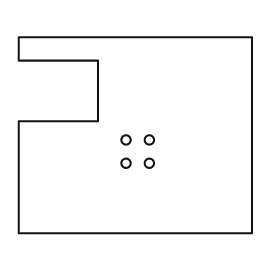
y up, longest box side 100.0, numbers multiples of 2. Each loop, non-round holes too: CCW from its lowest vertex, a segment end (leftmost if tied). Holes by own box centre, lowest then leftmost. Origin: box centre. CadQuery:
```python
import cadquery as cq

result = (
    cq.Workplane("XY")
    .moveTo(-50.0, -42.0)
    .lineTo(50.0, -42.0)
    .lineTo(50.0, 42.0)
    .lineTo(-50.0, 42.0)
    .lineTo(-50.0, 32.0)
    .lineTo(-16.0, 32.0)
    .lineTo(-16.0, 6.0)
    .lineTo(-50.0, 6.0)
    .close()
    .moveTo(-4.0, -12.0)
    .circle(2.0)
    .moveTo(6.0, -12.0)
    .circle(2.0)
    .moveTo(-4.0, -2.0)
    .circle(2.0)
    .moveTo(6.0, -2.0)
    .circle(2.0)
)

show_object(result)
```